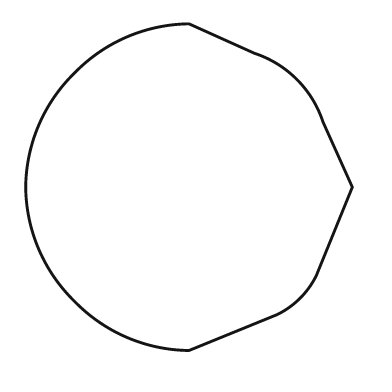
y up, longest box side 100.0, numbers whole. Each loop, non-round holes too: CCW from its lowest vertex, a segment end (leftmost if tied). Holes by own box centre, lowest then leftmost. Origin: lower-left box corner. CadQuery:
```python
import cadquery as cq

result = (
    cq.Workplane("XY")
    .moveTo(50.0, 0.0)
    .lineTo(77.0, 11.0)
    .threePointArc((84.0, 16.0), (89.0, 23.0))
    .lineTo(100.0, 50.0)
    .lineTo(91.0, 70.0)
    .threePointArc((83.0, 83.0), (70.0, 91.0))
    .lineTo(50.0, 100.0)
    .threePointArc((31.0, 96.0), (15.0, 85.0))
    .threePointArc((4.0, 69.0), (0.0, 50.0))
    .threePointArc((4.0, 31.0), (15.0, 15.0))
    .threePointArc((31.0, 4.0), (50.0, 0.0))
    .close()
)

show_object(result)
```